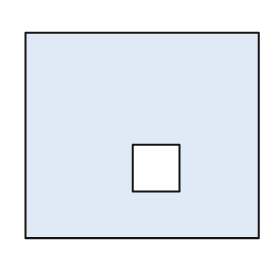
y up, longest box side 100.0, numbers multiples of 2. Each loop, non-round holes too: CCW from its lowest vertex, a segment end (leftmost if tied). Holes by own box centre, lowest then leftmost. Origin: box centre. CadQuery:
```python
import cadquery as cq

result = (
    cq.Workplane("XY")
    .moveTo(-50.0, -44.0)
    .lineTo(50.0, -44.0)
    .lineTo(50.0, 44.0)
    .lineTo(-50.0, 44.0)
    .close()
    .moveTo(-4.0, -24.0)
    .lineTo(16.0, -24.0)
    .lineTo(16.0, -4.0)
    .lineTo(-4.0, -4.0)
    .close()
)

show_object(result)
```